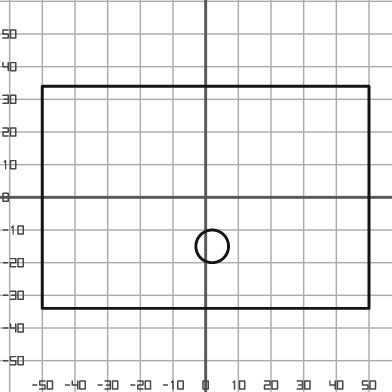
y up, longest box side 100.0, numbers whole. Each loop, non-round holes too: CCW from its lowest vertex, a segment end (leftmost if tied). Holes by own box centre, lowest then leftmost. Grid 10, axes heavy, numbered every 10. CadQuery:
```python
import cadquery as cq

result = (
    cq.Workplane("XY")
    .moveTo(-50.0, -34.0)
    .lineTo(50.0, -34.0)
    .lineTo(50.0, 34.0)
    .lineTo(-50.0, 34.0)
    .close()
    .moveTo(2.0, -15.0)
    .circle(5.0)
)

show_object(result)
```